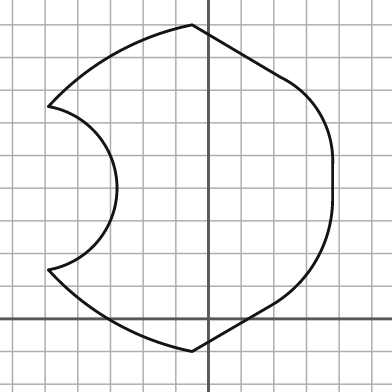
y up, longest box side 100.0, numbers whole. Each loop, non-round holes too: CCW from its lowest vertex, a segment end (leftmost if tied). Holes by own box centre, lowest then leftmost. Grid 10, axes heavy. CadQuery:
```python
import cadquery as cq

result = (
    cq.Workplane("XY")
    .moveTo(-5.0, -10.0)
    .lineTo(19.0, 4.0)
    .threePointArc((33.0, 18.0), (38.0, 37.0))
    .lineTo(38.0, 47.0)
    .threePointArc((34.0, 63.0), (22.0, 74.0))
    .lineTo(-5.0, 90.0)
    .threePointArc((-29.0, 81.0), (-49.0, 65.0))
    .threePointArc((-28.0, 40.0), (-49.0, 15.0))
    .threePointArc((-29.0, -1.0), (-5.0, -10.0))
    .close()
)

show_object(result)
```